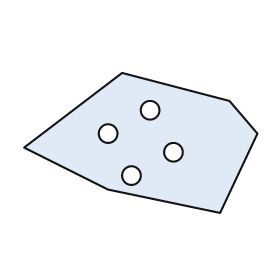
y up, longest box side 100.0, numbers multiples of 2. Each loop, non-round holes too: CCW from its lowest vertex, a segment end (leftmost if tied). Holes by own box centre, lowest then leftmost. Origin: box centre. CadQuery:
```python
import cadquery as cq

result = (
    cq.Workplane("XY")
    .moveTo(34.0, -30.0)
    .lineTo(50.0, 4.0)
    .lineTo(38.0, 18.0)
    .lineTo(-8.0, 30.0)
    .lineTo(-50.0, -2.0)
    .lineTo(-14.0, -20.0)
    .close()
    .moveTo(-4.0, -14.0)
    .circle(4.0)
    .moveTo(14.0, -4.0)
    .circle(4.0)
    .moveTo(-14.0, 4.0)
    .circle(4.0)
    .moveTo(4.0, 14.0)
    .circle(4.0)
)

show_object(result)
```